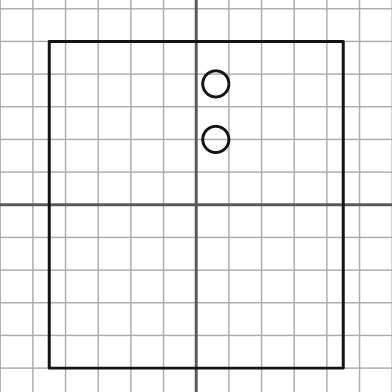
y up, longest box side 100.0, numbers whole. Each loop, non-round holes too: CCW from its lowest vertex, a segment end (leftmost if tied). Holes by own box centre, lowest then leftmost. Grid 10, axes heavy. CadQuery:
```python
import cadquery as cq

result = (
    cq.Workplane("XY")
    .moveTo(-45.0, -50.0)
    .lineTo(45.0, -50.0)
    .lineTo(45.0, 50.0)
    .lineTo(-45.0, 50.0)
    .close()
    .moveTo(6.0, 20.0)
    .circle(4.0)
    .moveTo(6.0, 37.0)
    .circle(4.0)
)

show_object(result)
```